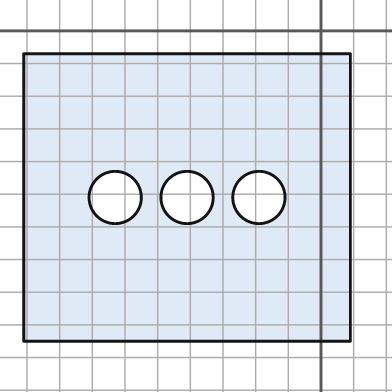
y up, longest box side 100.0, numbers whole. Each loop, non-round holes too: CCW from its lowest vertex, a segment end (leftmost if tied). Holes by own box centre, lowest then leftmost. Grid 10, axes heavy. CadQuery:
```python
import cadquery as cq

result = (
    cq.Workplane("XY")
    .moveTo(-91.0, -95.0)
    .lineTo(9.0, -95.0)
    .lineTo(9.0, -7.0)
    .lineTo(-91.0, -7.0)
    .close()
    .moveTo(-63.0, -51.0)
    .circle(8.0)
    .moveTo(-41.0, -51.0)
    .circle(8.0)
    .moveTo(-19.0, -51.0)
    .circle(8.0)
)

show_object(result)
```